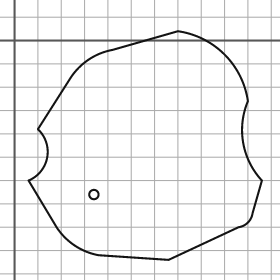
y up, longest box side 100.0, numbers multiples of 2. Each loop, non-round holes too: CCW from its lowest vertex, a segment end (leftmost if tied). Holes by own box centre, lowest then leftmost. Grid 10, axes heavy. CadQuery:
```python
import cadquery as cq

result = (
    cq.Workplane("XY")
    .moveTo(66.0, -94.0)
    .lineTo(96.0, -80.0)
    .threePointArc((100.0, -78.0), (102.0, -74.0))
    .lineTo(106.0, -60.0)
    .threePointArc((98.0, -44.0), (100.0, -26.0))
    .threePointArc((90.0, -6.0), (70.0, 4.0))
    .lineTo(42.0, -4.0)
    .threePointArc((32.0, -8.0), (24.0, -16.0))
    .lineTo(10.0, -38.0)
    .threePointArc((14.0, -50.0), (6.0, -60.0))
    .lineTo(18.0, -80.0)
    .threePointArc((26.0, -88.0), (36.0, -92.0))
    .close()
    .moveTo(34.0, -66.0)
    .circle(2.0)
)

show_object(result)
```